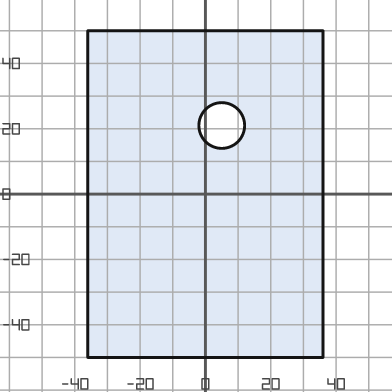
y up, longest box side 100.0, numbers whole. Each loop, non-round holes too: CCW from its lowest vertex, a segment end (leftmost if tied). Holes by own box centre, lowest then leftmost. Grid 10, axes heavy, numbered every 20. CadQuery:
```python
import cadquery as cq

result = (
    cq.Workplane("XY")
    .moveTo(-36.0, -50.0)
    .lineTo(36.0, -50.0)
    .lineTo(36.0, 50.0)
    .lineTo(-36.0, 50.0)
    .close()
    .moveTo(5.0, 21.0)
    .circle(7.0)
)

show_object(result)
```